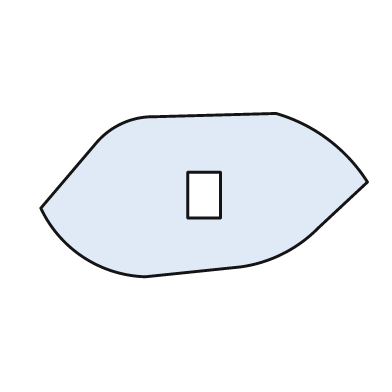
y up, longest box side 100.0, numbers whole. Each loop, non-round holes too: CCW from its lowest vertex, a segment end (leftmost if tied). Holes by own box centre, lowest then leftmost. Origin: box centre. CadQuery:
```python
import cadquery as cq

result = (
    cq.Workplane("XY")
    .moveTo(-18.0, -25.0)
    .lineTo(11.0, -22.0)
    .threePointArc((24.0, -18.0), (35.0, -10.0))
    .lineTo(50.0, 4.0)
    .threePointArc((38.0, 17.0), (22.0, 25.0))
    .lineTo(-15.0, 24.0)
    .threePointArc((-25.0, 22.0), (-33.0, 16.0))
    .lineTo(-50.0, -4.0)
    .threePointArc((-37.0, -19.0), (-18.0, -25.0))
    .close()
    .moveTo(-5.0, -7.0)
    .lineTo(5.0, -7.0)
    .lineTo(5.0, 7.0)
    .lineTo(-5.0, 7.0)
    .close()
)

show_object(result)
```